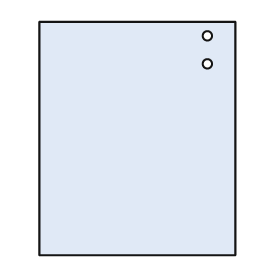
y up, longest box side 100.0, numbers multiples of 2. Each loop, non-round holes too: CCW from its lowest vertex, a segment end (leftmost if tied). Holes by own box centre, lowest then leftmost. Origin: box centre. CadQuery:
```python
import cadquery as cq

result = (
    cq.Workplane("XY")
    .moveTo(-42.0, -50.0)
    .lineTo(42.0, -50.0)
    .lineTo(42.0, 50.0)
    .lineTo(-42.0, 50.0)
    .close()
    .moveTo(30.0, 32.0)
    .circle(2.0)
    .moveTo(30.0, 44.0)
    .circle(2.0)
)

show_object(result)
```